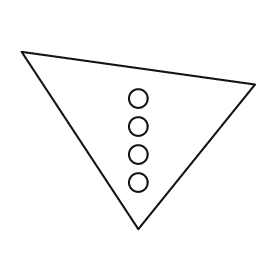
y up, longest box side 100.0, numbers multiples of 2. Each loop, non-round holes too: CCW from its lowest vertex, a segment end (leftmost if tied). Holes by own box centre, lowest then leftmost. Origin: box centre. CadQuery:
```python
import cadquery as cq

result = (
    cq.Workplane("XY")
    .moveTo(0.0, -38.0)
    .lineTo(50.0, 24.0)
    .lineTo(-50.0, 38.0)
    .close()
    .moveTo(0.0, -18.0)
    .circle(4.0)
    .moveTo(0.0, -6.0)
    .circle(4.0)
    .moveTo(0.0, 6.0)
    .circle(4.0)
    .moveTo(0.0, 18.0)
    .circle(4.0)
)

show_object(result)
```